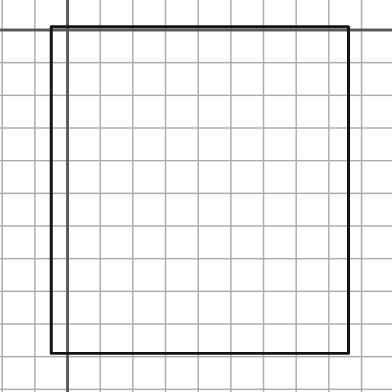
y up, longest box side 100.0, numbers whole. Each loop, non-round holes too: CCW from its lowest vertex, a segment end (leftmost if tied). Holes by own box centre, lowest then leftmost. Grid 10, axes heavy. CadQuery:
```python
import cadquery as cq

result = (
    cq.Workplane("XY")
    .moveTo(-5.0, -99.0)
    .lineTo(86.0, -99.0)
    .lineTo(86.0, 1.0)
    .lineTo(-5.0, 1.0)
    .close()
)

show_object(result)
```